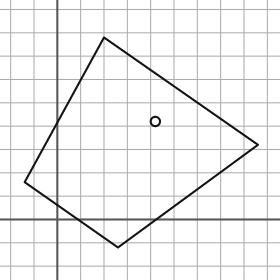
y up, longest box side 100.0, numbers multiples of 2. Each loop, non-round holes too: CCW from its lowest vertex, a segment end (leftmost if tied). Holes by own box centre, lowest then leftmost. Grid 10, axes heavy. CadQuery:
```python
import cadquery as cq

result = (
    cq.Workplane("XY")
    .moveTo(26.0, -12.0)
    .lineTo(86.0, 32.0)
    .lineTo(20.0, 78.0)
    .lineTo(-14.0, 16.0)
    .close()
    .moveTo(42.0, 42.0)
    .circle(2.0)
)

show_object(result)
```